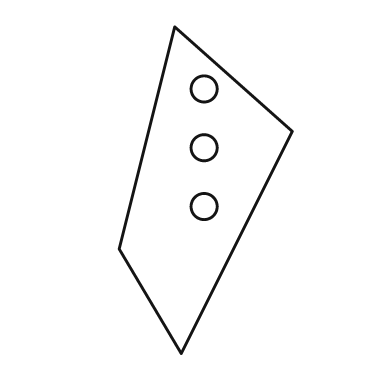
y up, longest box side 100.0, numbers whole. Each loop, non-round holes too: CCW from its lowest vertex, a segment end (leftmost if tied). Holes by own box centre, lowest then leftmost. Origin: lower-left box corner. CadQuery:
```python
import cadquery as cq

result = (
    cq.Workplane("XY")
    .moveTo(19.0, 0.0)
    .lineTo(53.0, 68.0)
    .lineTo(17.0, 100.0)
    .lineTo(0.0, 32.0)
    .close()
    .moveTo(26.0, 45.0)
    .circle(4.0)
    .moveTo(26.0, 63.0)
    .circle(4.0)
    .moveTo(26.0, 81.0)
    .circle(4.0)
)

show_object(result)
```